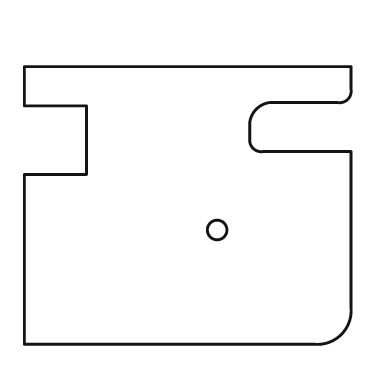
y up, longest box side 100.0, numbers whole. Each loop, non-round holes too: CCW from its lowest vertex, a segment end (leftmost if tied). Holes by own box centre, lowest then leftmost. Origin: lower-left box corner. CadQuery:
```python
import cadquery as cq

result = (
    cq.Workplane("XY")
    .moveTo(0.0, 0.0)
    .lineTo(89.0, 0.0)
    .threePointArc((97.0, 3.0), (100.0, 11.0))
    .lineTo(100.0, 59.0)
    .lineTo(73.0, 59.0)
    .threePointArc((70.0, 60.0), (69.0, 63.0))
    .lineTo(69.0, 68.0)
    .threePointArc((71.0, 72.0), (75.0, 74.0))
    .lineTo(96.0, 74.0)
    .threePointArc((99.0, 75.0), (100.0, 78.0))
    .lineTo(100.0, 85.0)
    .lineTo(0.0, 85.0)
    .lineTo(0.0, 73.0)
    .lineTo(19.0, 73.0)
    .lineTo(19.0, 52.0)
    .lineTo(0.0, 52.0)
    .close()
    .moveTo(59.0, 35.0)
    .circle(3.0)
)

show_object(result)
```